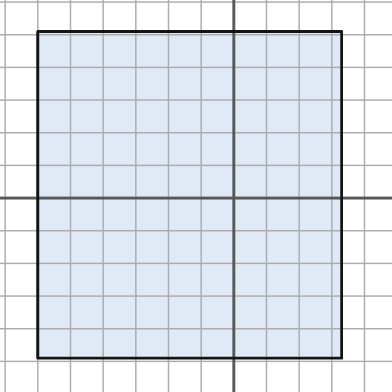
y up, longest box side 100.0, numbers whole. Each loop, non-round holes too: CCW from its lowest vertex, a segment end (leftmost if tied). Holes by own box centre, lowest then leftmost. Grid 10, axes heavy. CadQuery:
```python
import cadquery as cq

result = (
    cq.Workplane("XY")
    .moveTo(-60.0, -49.0)
    .lineTo(33.0, -49.0)
    .lineTo(33.0, 51.0)
    .lineTo(-60.0, 51.0)
    .close()
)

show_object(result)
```